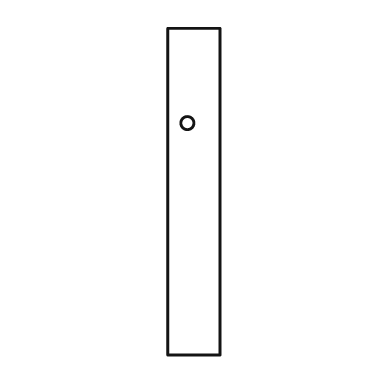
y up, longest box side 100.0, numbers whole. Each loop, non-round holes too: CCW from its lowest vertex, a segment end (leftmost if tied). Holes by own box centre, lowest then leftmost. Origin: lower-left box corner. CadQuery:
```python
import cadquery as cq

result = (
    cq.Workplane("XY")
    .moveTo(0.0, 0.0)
    .lineTo(16.0, 0.0)
    .lineTo(16.0, 100.0)
    .lineTo(0.0, 100.0)
    .close()
    .moveTo(6.0, 71.0)
    .circle(2.0)
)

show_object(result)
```